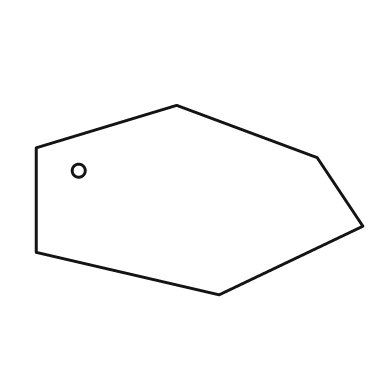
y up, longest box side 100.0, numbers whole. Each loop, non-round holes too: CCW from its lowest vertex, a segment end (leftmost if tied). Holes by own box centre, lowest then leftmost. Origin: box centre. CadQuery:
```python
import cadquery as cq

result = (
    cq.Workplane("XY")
    .moveTo(6.0, -29.0)
    .lineTo(50.0, -8.0)
    .lineTo(36.0, 13.0)
    .lineTo(-7.0, 29.0)
    .lineTo(-50.0, 16.0)
    .lineTo(-50.0, -16.0)
    .close()
    .moveTo(-37.0, 9.0)
    .circle(2.0)
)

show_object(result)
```